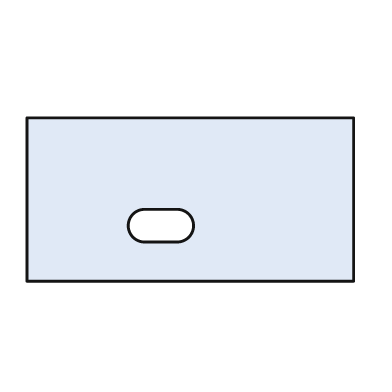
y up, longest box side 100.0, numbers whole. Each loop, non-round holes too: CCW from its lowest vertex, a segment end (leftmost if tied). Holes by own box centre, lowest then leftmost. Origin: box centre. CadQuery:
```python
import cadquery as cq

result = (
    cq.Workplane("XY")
    .moveTo(-50.0, -25.0)
    .lineTo(50.0, -25.0)
    .lineTo(50.0, 25.0)
    .lineTo(-50.0, 25.0)
    .close()
    .moveTo(-14.0, -13.0)
    .lineTo(-4.0, -13.0)
    .threePointArc((1.0, -8.0), (-4.0, -3.0))
    .lineTo(-14.0, -3.0)
    .threePointArc((-19.0, -8.0), (-14.0, -13.0))
    .close()
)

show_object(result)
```